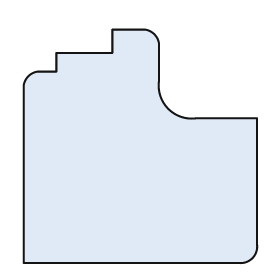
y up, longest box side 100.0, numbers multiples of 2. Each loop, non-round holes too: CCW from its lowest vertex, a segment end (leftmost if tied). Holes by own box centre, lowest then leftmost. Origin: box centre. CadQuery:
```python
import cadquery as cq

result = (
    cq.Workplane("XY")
    .moveTo(-50.0, -50.0)
    .lineTo(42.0, -50.0)
    .threePointArc((48.0, -48.0), (50.0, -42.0))
    .lineTo(50.0, 12.0)
    .lineTo(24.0, 12.0)
    .threePointArc((12.0, 16.0), (8.0, 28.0))
    .lineTo(8.0, 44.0)
    .threePointArc((6.0, 48.0), (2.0, 50.0))
    .lineTo(-12.0, 50.0)
    .lineTo(-12.0, 40.0)
    .lineTo(-36.0, 40.0)
    .lineTo(-36.0, 32.0)
    .lineTo(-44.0, 32.0)
    .threePointArc((-48.0, 30.0), (-50.0, 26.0))
    .close()
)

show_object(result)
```